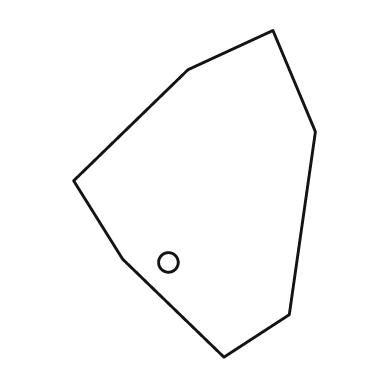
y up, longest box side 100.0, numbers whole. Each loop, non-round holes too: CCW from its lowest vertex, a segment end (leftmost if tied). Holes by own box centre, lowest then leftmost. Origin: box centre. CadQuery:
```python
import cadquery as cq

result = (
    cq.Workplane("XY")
    .moveTo(9.0, -50.0)
    .lineTo(29.0, -37.0)
    .lineTo(37.0, 19.0)
    .lineTo(24.0, 50.0)
    .lineTo(-2.0, 38.0)
    .lineTo(-37.0, 4.0)
    .lineTo(-22.0, -20.0)
    .close()
    .moveTo(-8.0, -21.0)
    .circle(3.0)
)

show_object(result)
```